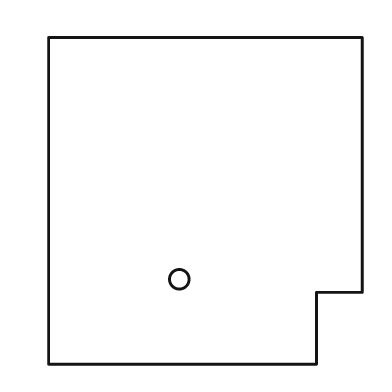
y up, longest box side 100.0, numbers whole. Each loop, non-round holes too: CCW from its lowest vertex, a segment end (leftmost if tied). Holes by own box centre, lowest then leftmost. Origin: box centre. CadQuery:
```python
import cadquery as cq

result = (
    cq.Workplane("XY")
    .moveTo(-48.0, -50.0)
    .lineTo(34.0, -50.0)
    .lineTo(34.0, -28.0)
    .lineTo(48.0, -28.0)
    .lineTo(48.0, 50.0)
    .lineTo(-48.0, 50.0)
    .close()
    .moveTo(-8.0, -24.0)
    .circle(3.0)
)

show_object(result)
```